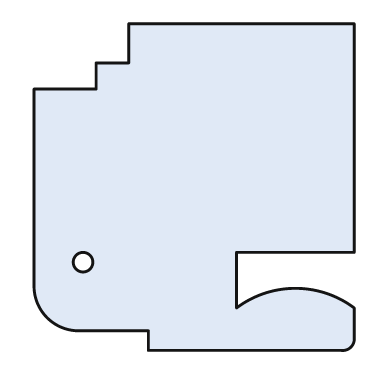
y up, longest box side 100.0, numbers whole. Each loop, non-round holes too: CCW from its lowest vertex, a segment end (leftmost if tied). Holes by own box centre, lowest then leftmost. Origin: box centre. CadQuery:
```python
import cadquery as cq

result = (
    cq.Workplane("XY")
    .moveTo(-14.0, -50.0)
    .lineTo(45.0, -50.0)
    .threePointArc((48.0, -49.0), (49.0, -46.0))
    .lineTo(49.0, -37.0)
    .threePointArc((31.0, -31.0), (13.0, -37.0))
    .lineTo(13.0, -20.0)
    .lineTo(49.0, -20.0)
    .lineTo(49.0, 50.0)
    .lineTo(-20.0, 50.0)
    .lineTo(-20.0, 38.0)
    .lineTo(-30.0, 38.0)
    .lineTo(-30.0, 30.0)
    .lineTo(-49.0, 30.0)
    .lineTo(-49.0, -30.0)
    .threePointArc((-45.0, -40.0), (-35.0, -44.0))
    .lineTo(-14.0, -44.0)
    .close()
    .moveTo(-34.0, -23.0)
    .circle(3.0)
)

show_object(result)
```